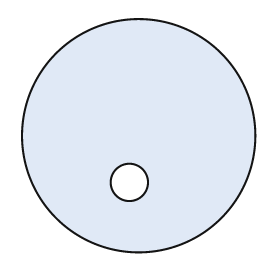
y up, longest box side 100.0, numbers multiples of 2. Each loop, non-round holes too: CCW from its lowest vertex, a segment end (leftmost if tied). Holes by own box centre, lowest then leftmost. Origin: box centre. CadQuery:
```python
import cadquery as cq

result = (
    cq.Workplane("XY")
    .moveTo(0.0, 0.0)
    .circle(50.0)
    .moveTo(-4.0, -20.0)
    .circle(8.0)
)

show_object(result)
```